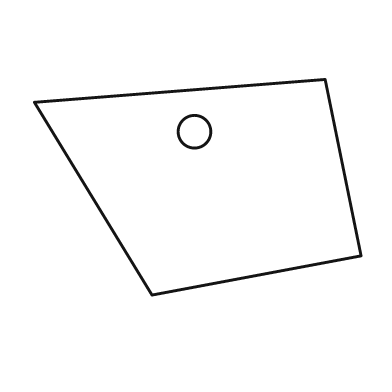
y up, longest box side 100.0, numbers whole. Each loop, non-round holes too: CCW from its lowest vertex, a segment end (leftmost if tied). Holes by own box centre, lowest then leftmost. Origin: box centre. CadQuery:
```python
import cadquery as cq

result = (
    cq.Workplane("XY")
    .moveTo(-14.0, -33.0)
    .lineTo(50.0, -21.0)
    .lineTo(39.0, 33.0)
    .lineTo(-50.0, 26.0)
    .close()
    .moveTo(-1.0, 17.0)
    .circle(5.0)
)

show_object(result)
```